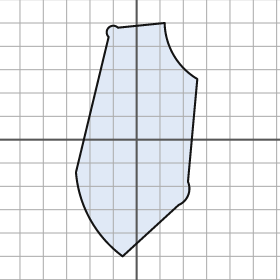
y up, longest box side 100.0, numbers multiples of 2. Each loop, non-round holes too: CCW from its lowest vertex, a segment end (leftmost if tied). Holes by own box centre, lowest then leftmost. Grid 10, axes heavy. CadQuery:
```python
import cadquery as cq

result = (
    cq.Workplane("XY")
    .moveTo(-6.0, -50.0)
    .lineTo(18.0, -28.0)
    .threePointArc((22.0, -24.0), (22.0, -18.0))
    .lineTo(26.0, 26.0)
    .threePointArc((16.0, 36.0), (12.0, 50.0))
    .lineTo(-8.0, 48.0)
    .threePointArc((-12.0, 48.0), (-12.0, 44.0))
    .lineTo(-26.0, -14.0)
    .threePointArc((-20.0, -34.0), (-6.0, -50.0))
    .close()
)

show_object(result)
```